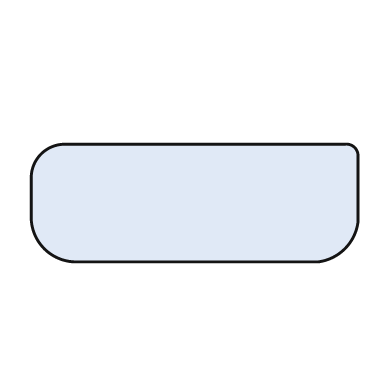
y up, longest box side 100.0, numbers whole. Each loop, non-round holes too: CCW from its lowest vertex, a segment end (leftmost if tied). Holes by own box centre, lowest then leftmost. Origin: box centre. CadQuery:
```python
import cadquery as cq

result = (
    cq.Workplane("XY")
    .moveTo(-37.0, -18.0)
    .lineTo(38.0, -18.0)
    .threePointArc((46.0, -14.0), (50.0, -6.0))
    .lineTo(50.0, 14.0)
    .threePointArc((49.0, 17.0), (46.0, 18.0))
    .lineTo(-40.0, 18.0)
    .threePointArc((-47.0, 15.0), (-50.0, 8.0))
    .lineTo(-50.0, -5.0)
    .threePointArc((-46.0, -14.0), (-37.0, -18.0))
    .close()
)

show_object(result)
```